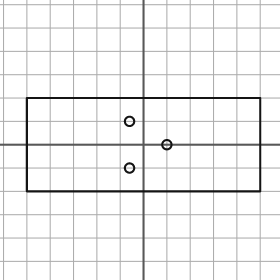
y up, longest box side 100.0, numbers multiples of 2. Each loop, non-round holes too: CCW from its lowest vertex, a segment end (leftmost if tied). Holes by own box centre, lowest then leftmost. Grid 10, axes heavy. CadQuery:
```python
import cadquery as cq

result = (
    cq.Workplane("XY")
    .moveTo(-50.0, -20.0)
    .lineTo(50.0, -20.0)
    .lineTo(50.0, 20.0)
    .lineTo(-50.0, 20.0)
    .close()
    .moveTo(-6.0, -10.0)
    .circle(2.0)
    .moveTo(10.0, 0.0)
    .circle(2.0)
    .moveTo(-6.0, 10.0)
    .circle(2.0)
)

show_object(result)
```